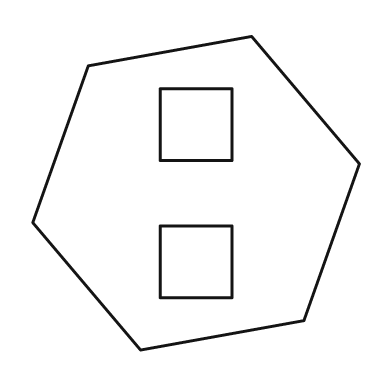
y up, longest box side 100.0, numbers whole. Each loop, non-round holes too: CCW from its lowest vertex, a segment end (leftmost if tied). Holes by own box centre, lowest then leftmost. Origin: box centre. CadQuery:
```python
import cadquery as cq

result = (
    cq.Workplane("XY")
    .moveTo(-17.0, -48.0)
    .lineTo(33.0, -39.0)
    .lineTo(50.0, 9.0)
    .lineTo(17.0, 48.0)
    .lineTo(-33.0, 39.0)
    .lineTo(-50.0, -9.0)
    .close()
    .moveTo(-11.0, -32.0)
    .lineTo(11.0, -32.0)
    .lineTo(11.0, -10.0)
    .lineTo(-11.0, -10.0)
    .close()
    .moveTo(-11.0, 10.0)
    .lineTo(11.0, 10.0)
    .lineTo(11.0, 32.0)
    .lineTo(-11.0, 32.0)
    .close()
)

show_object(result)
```